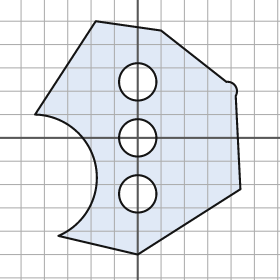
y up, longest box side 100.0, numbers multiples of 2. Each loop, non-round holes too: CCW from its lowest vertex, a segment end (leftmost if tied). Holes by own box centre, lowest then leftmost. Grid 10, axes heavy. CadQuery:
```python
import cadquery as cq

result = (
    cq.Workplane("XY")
    .moveTo(0.0, -50.0)
    .lineTo(44.0, -22.0)
    .lineTo(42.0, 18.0)
    .threePointArc((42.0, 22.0), (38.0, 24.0))
    .lineTo(10.0, 46.0)
    .lineTo(-18.0, 50.0)
    .lineTo(-44.0, 10.0)
    .threePointArc((-18.0, -12.0), (-34.0, -42.0))
    .close()
    .moveTo(0.0, -24.0)
    .circle(8.0)
    .moveTo(0.0, 0.0)
    .circle(8.0)
    .moveTo(0.0, 24.0)
    .circle(8.0)
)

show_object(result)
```